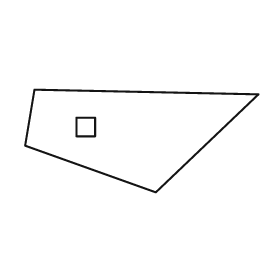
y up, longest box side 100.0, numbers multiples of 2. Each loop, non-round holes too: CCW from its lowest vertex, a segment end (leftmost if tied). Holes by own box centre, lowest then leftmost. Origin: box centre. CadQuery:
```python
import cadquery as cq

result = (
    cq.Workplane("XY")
    .moveTo(6.0, -22.0)
    .lineTo(50.0, 20.0)
    .lineTo(-46.0, 22.0)
    .lineTo(-50.0, -2.0)
    .close()
    .moveTo(-28.0, 2.0)
    .lineTo(-20.0, 2.0)
    .lineTo(-20.0, 10.0)
    .lineTo(-28.0, 10.0)
    .close()
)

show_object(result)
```